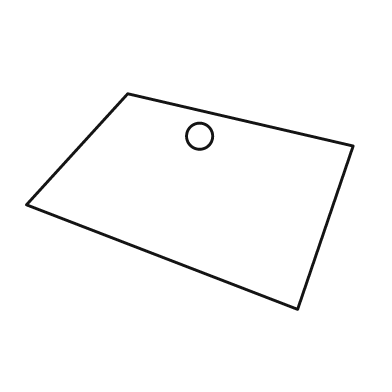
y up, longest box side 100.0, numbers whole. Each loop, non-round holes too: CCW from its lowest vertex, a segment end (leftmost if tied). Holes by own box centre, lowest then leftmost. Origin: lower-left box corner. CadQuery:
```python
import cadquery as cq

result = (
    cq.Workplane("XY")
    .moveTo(83.0, 0.0)
    .lineTo(100.0, 50.0)
    .lineTo(31.0, 66.0)
    .lineTo(0.0, 32.0)
    .close()
    .moveTo(53.0, 53.0)
    .circle(4.0)
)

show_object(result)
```